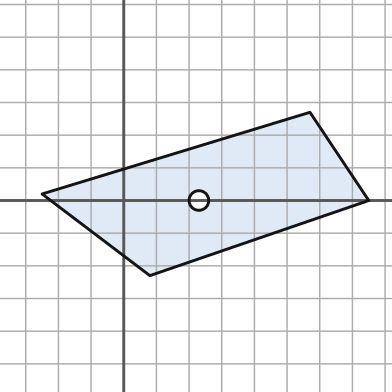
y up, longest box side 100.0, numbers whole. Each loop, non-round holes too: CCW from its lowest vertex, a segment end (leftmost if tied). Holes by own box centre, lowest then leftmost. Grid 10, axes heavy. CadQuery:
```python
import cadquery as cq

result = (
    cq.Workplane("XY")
    .moveTo(8.0, -23.0)
    .lineTo(75.0, 0.0)
    .lineTo(57.0, 27.0)
    .lineTo(-25.0, 2.0)
    .close()
    .moveTo(23.0, 0.0)
    .circle(3.0)
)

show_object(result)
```